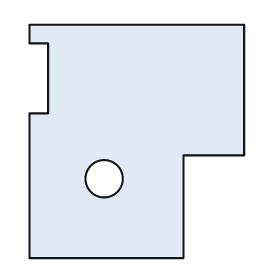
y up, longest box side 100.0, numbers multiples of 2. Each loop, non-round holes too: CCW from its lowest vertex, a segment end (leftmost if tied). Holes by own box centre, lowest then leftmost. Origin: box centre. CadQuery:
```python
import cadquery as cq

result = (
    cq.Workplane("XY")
    .moveTo(-46.0, -50.0)
    .lineTo(20.0, -50.0)
    .lineTo(20.0, -6.0)
    .lineTo(46.0, -6.0)
    .lineTo(46.0, 50.0)
    .lineTo(-46.0, 50.0)
    .lineTo(-46.0, 42.0)
    .lineTo(-38.0, 42.0)
    .lineTo(-38.0, 12.0)
    .lineTo(-46.0, 12.0)
    .close()
    .moveTo(-14.0, -16.0)
    .circle(8.0)
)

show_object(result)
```